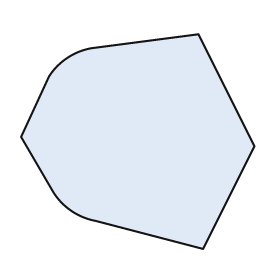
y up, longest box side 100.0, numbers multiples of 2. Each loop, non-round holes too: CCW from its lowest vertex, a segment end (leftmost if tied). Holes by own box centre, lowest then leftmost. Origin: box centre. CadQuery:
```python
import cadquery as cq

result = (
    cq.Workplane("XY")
    .moveTo(28.0, -46.0)
    .lineTo(50.0, -2.0)
    .lineTo(26.0, 46.0)
    .lineTo(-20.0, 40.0)
    .threePointArc((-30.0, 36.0), (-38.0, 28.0))
    .lineTo(-50.0, 2.0)
    .lineTo(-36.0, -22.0)
    .threePointArc((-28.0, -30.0), (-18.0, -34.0))
    .close()
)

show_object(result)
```